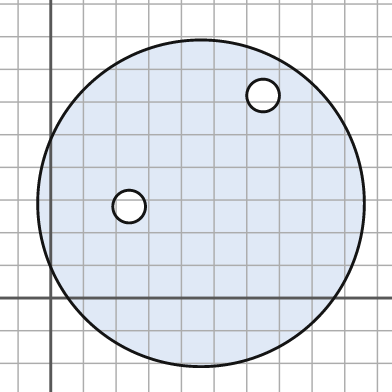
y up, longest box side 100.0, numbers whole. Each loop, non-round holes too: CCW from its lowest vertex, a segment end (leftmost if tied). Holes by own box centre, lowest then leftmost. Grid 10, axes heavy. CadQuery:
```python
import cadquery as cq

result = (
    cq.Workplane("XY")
    .moveTo(46.0, 29.0)
    .circle(50.0)
    .moveTo(24.0, 28.0)
    .circle(5.0)
    .moveTo(65.0, 62.0)
    .circle(5.0)
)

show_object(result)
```